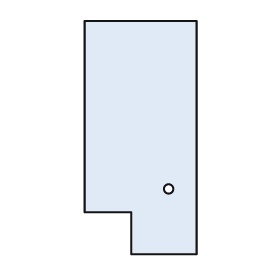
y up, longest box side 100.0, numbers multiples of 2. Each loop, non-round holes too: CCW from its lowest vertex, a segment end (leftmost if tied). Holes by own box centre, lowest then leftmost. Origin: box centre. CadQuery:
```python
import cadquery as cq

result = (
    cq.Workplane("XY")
    .moveTo(-4.0, -50.0)
    .lineTo(24.0, -50.0)
    .lineTo(24.0, 50.0)
    .lineTo(-24.0, 50.0)
    .lineTo(-24.0, -32.0)
    .lineTo(-4.0, -32.0)
    .close()
    .moveTo(12.0, -22.0)
    .circle(2.0)
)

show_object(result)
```